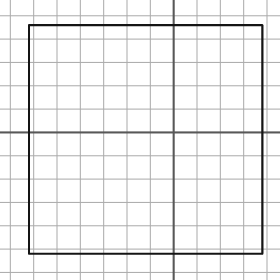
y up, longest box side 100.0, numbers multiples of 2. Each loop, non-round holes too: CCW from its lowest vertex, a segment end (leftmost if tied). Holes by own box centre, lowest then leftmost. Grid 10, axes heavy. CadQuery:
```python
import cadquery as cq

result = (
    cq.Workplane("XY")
    .moveTo(-62.0, -52.0)
    .lineTo(38.0, -52.0)
    .lineTo(38.0, 46.0)
    .lineTo(-62.0, 46.0)
    .close()
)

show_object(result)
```